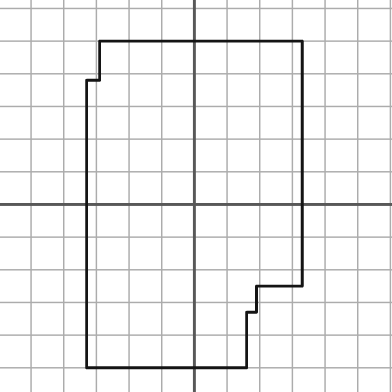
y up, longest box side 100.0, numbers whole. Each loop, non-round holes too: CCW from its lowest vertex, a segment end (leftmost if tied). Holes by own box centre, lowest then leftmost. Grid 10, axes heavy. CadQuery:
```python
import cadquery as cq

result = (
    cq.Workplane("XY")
    .moveTo(-33.0, -50.0)
    .lineTo(16.0, -50.0)
    .lineTo(16.0, -33.0)
    .lineTo(19.0, -33.0)
    .lineTo(19.0, -25.0)
    .lineTo(33.0, -25.0)
    .lineTo(33.0, 50.0)
    .lineTo(-29.0, 50.0)
    .lineTo(-29.0, 38.0)
    .lineTo(-33.0, 38.0)
    .close()
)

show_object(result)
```